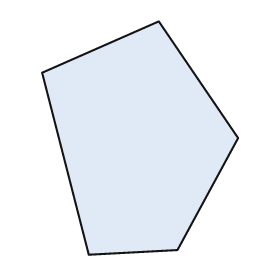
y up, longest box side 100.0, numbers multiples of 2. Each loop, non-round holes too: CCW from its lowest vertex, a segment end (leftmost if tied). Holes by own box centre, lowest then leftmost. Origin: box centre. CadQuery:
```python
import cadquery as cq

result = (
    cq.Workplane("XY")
    .moveTo(-22.0, -50.0)
    .lineTo(16.0, -48.0)
    .lineTo(42.0, 0.0)
    .lineTo(8.0, 50.0)
    .lineTo(-42.0, 28.0)
    .close()
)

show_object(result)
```